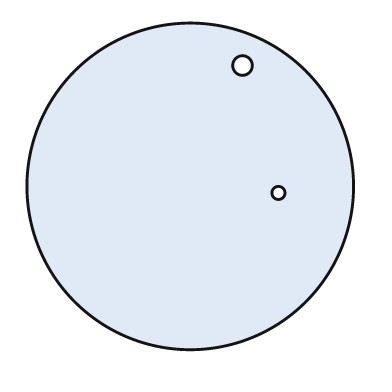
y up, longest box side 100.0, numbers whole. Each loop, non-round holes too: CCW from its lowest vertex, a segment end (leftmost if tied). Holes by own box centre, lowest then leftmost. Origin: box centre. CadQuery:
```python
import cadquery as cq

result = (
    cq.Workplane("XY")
    .moveTo(0.0, 0.0)
    .circle(50.0)
    .moveTo(27.0, -2.0)
    .circle(2.0)
    .moveTo(16.0, 37.0)
    .circle(3.0)
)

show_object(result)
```